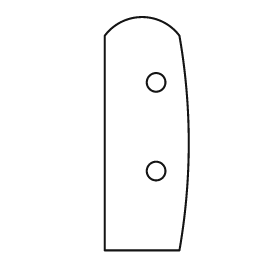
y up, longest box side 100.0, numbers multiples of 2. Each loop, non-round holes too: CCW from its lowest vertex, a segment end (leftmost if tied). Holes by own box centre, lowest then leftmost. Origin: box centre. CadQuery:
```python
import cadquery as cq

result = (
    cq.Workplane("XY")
    .moveTo(-18.0, -50.0)
    .lineTo(14.0, -50.0)
    .threePointArc((18.0, -4.0), (14.0, 42.0))
    .threePointArc((-2.0, 50.0), (-18.0, 42.0))
    .close()
    .moveTo(4.0, -16.0)
    .circle(4.0)
    .moveTo(4.0, 22.0)
    .circle(4.0)
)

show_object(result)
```